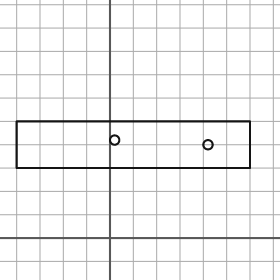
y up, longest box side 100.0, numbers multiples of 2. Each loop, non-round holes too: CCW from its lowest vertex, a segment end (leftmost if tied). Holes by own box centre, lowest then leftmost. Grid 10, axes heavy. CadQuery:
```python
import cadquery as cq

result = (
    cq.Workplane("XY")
    .moveTo(-40.0, 30.0)
    .lineTo(60.0, 30.0)
    .lineTo(60.0, 50.0)
    .lineTo(-40.0, 50.0)
    .close()
    .moveTo(42.0, 40.0)
    .circle(2.0)
    .moveTo(2.0, 42.0)
    .circle(2.0)
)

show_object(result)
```